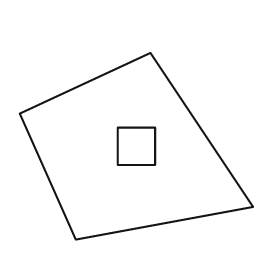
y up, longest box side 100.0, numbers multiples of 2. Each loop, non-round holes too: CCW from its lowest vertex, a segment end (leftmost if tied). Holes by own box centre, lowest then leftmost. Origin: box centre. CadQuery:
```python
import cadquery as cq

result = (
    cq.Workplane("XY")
    .moveTo(-26.0, -40.0)
    .lineTo(50.0, -26.0)
    .lineTo(6.0, 40.0)
    .lineTo(-50.0, 14.0)
    .close()
    .moveTo(-8.0, -8.0)
    .lineTo(8.0, -8.0)
    .lineTo(8.0, 8.0)
    .lineTo(-8.0, 8.0)
    .close()
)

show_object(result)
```